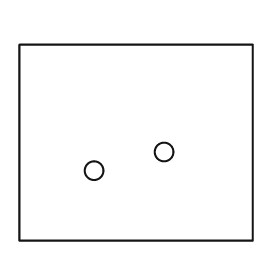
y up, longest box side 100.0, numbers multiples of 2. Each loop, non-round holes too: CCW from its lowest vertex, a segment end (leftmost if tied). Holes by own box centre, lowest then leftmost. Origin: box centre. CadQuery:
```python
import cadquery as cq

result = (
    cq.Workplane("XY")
    .moveTo(-50.0, -42.0)
    .lineTo(50.0, -42.0)
    .lineTo(50.0, 42.0)
    .lineTo(-50.0, 42.0)
    .close()
    .moveTo(-18.0, -12.0)
    .circle(4.0)
    .moveTo(12.0, -4.0)
    .circle(4.0)
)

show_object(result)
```